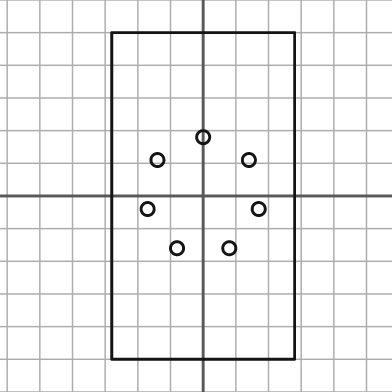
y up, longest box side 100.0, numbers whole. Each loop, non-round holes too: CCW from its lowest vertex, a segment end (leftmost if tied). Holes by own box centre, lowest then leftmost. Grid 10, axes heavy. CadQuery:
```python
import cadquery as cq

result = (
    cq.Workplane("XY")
    .moveTo(-28.0, -50.0)
    .lineTo(28.0, -50.0)
    .lineTo(28.0, 50.0)
    .lineTo(-28.0, 50.0)
    .close()
    .moveTo(-8.0, -16.0)
    .circle(2.0)
    .moveTo(8.0, -16.0)
    .circle(2.0)
    .moveTo(-17.0, -4.0)
    .circle(2.0)
    .moveTo(17.0, -4.0)
    .circle(2.0)
    .moveTo(-14.0, 11.0)
    .circle(2.0)
    .moveTo(14.0, 11.0)
    .circle(2.0)
    .moveTo(0.0, 18.0)
    .circle(2.0)
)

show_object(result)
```